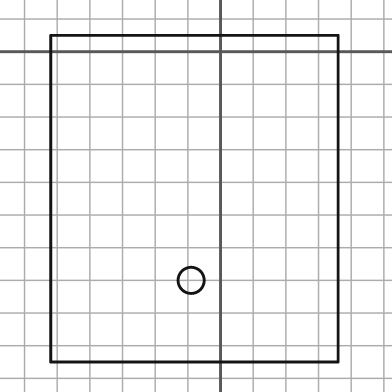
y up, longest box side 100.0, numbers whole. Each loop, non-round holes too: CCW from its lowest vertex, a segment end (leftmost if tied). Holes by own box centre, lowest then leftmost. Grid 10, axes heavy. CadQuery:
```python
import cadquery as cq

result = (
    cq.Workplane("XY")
    .moveTo(-52.0, -95.0)
    .lineTo(36.0, -95.0)
    .lineTo(36.0, 5.0)
    .lineTo(-52.0, 5.0)
    .close()
    .moveTo(-9.0, -70.0)
    .circle(4.0)
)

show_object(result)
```